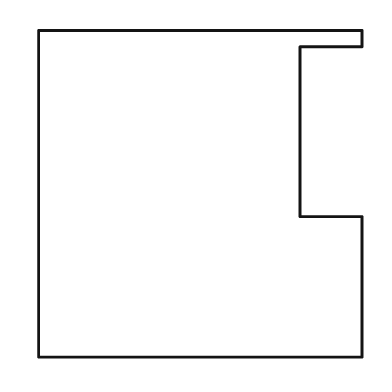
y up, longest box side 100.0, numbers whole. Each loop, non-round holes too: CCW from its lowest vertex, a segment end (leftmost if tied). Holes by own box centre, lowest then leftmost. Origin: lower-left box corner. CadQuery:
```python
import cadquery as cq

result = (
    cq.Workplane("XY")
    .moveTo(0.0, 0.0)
    .lineTo(99.0, 0.0)
    .lineTo(99.0, 43.0)
    .lineTo(80.0, 43.0)
    .lineTo(80.0, 95.0)
    .lineTo(99.0, 95.0)
    .lineTo(99.0, 100.0)
    .lineTo(0.0, 100.0)
    .close()
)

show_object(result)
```